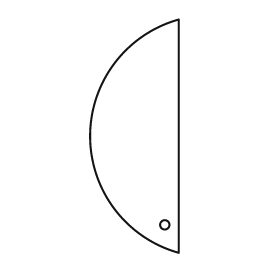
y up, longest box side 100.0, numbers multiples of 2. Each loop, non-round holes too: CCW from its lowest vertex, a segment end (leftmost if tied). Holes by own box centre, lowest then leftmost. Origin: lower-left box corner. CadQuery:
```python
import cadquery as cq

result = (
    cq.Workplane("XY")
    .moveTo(38.0, 0.0)
    .lineTo(38.0, 100.0)
    .threePointArc((0.0, 50.0), (38.0, 0.0))
    .close()
    .moveTo(32.0, 12.0)
    .circle(2.0)
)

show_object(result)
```